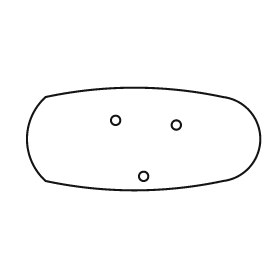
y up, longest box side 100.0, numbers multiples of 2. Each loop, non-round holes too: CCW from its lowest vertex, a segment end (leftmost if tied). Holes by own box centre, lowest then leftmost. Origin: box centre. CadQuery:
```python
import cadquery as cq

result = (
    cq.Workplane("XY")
    .moveTo(-42.0, -18.0)
    .threePointArc((-4.0, -22.0), (34.0, -18.0))
    .threePointArc((50.0, 0.0), (34.0, 18.0))
    .threePointArc((-4.0, 22.0), (-42.0, 18.0))
    .threePointArc((-50.0, 0.0), (-42.0, -18.0))
    .close()
    .moveTo(0.0, -16.0)
    .circle(2.0)
    .moveTo(14.0, 6.0)
    .circle(2.0)
    .moveTo(-12.0, 8.0)
    .circle(2.0)
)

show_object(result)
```